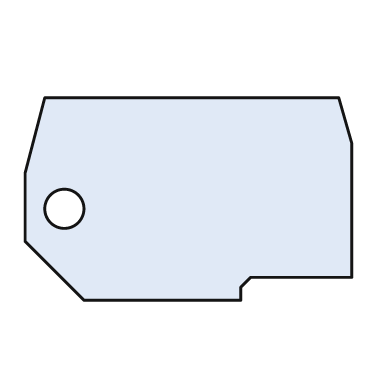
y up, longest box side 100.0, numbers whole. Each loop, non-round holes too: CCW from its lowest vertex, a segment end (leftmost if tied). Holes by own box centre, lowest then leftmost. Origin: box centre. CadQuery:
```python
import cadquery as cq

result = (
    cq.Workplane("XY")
    .moveTo(-32.0, -31.0)
    .lineTo(16.0, -31.0)
    .lineTo(16.0, -27.0)
    .lineTo(19.0, -24.0)
    .lineTo(50.0, -24.0)
    .lineTo(50.0, 17.0)
    .lineTo(46.0, 31.0)
    .lineTo(-44.0, 31.0)
    .lineTo(-50.0, 8.0)
    .lineTo(-50.0, -13.0)
    .close()
    .moveTo(-38.0, -3.0)
    .circle(6.0)
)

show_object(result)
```